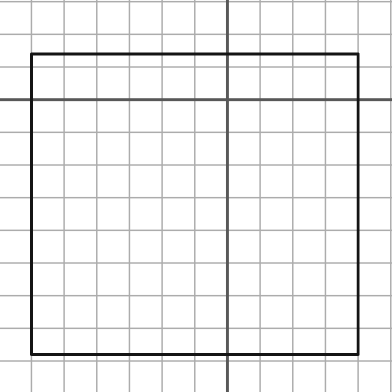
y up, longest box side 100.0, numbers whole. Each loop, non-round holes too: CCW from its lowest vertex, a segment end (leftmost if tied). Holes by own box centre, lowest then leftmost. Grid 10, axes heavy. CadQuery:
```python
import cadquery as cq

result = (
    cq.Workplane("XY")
    .moveTo(-60.0, -78.0)
    .lineTo(40.0, -78.0)
    .lineTo(40.0, 14.0)
    .lineTo(-60.0, 14.0)
    .close()
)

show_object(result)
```